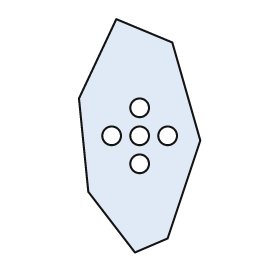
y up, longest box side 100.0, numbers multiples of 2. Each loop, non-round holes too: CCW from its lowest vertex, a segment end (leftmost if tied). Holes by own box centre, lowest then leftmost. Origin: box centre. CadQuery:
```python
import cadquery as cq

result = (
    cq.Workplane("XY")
    .moveTo(-2.0, -50.0)
    .lineTo(12.0, -44.0)
    .lineTo(26.0, -2.0)
    .lineTo(14.0, 40.0)
    .lineTo(-10.0, 50.0)
    .lineTo(-26.0, 16.0)
    .lineTo(-22.0, -24.0)
    .close()
    .moveTo(0.0, -12.0)
    .circle(4.0)
    .moveTo(-12.0, 0.0)
    .circle(4.0)
    .moveTo(0.0, 0.0)
    .circle(4.0)
    .moveTo(12.0, 0.0)
    .circle(4.0)
    .moveTo(0.0, 12.0)
    .circle(4.0)
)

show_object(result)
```